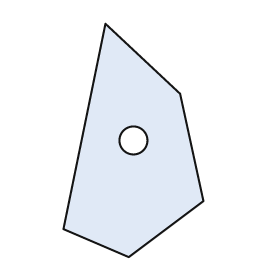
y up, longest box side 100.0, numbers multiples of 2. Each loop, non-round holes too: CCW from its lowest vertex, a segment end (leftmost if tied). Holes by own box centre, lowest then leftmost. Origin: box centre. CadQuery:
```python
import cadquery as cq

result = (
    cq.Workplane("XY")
    .moveTo(-2.0, -50.0)
    .lineTo(30.0, -26.0)
    .lineTo(20.0, 20.0)
    .lineTo(-12.0, 50.0)
    .lineTo(-30.0, -38.0)
    .close()
    .moveTo(0.0, 0.0)
    .circle(6.0)
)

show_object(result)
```